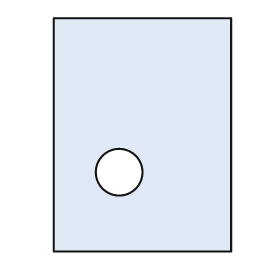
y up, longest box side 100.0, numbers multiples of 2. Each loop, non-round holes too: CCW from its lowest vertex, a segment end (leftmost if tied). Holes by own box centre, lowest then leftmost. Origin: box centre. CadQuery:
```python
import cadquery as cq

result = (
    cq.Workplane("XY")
    .moveTo(-38.0, -50.0)
    .lineTo(38.0, -50.0)
    .lineTo(38.0, 50.0)
    .lineTo(-38.0, 50.0)
    .close()
    .moveTo(-10.0, -16.0)
    .circle(10.0)
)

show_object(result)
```